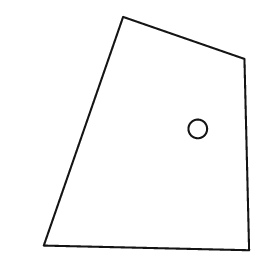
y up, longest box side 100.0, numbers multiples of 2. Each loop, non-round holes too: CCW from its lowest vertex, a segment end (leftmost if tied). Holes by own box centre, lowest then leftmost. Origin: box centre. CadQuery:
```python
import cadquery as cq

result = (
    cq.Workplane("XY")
    .moveTo(44.0, -50.0)
    .lineTo(42.0, 32.0)
    .lineTo(-10.0, 50.0)
    .lineTo(-44.0, -48.0)
    .close()
    .moveTo(22.0, 2.0)
    .circle(4.0)
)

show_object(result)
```